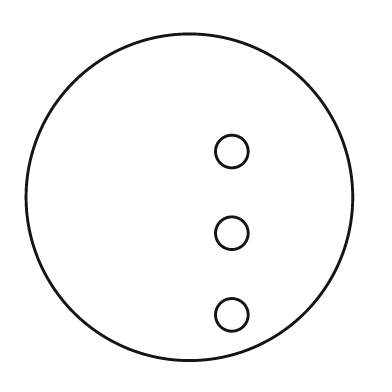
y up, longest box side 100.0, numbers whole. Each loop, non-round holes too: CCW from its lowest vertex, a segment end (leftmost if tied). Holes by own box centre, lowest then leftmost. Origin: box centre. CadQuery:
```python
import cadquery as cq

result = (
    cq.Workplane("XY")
    .moveTo(0.0, 0.0)
    .circle(50.0)
    .moveTo(13.0, -36.0)
    .circle(5.0)
    .moveTo(13.0, -11.0)
    .circle(5.0)
    .moveTo(13.0, 14.0)
    .circle(5.0)
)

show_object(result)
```